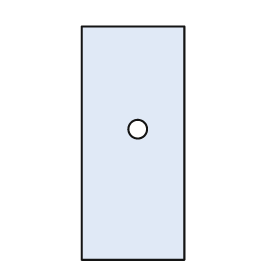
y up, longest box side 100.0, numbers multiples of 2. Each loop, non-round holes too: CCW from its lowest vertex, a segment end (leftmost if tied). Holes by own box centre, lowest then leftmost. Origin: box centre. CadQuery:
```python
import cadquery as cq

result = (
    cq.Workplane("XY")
    .moveTo(-22.0, -50.0)
    .lineTo(22.0, -50.0)
    .lineTo(22.0, 50.0)
    .lineTo(-22.0, 50.0)
    .close()
    .moveTo(2.0, 6.0)
    .circle(4.0)
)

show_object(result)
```